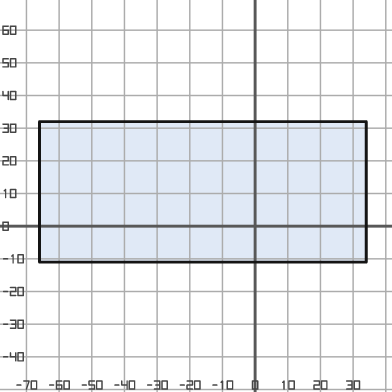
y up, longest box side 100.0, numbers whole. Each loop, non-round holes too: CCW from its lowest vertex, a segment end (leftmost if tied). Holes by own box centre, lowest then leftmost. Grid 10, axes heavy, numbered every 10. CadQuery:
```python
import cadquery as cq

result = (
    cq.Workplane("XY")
    .moveTo(-66.0, -11.0)
    .lineTo(34.0, -11.0)
    .lineTo(34.0, 32.0)
    .lineTo(-66.0, 32.0)
    .close()
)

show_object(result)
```